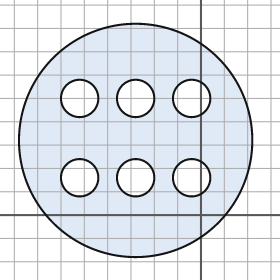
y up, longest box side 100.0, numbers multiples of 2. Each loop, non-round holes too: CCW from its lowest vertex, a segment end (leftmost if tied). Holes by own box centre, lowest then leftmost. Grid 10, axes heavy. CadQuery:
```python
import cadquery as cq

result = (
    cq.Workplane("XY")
    .moveTo(-28.0, 32.0)
    .circle(50.0)
    .moveTo(-52.0, 16.0)
    .circle(8.0)
    .moveTo(-28.0, 16.0)
    .circle(8.0)
    .moveTo(-4.0, 16.0)
    .circle(8.0)
    .moveTo(-52.0, 50.0)
    .circle(8.0)
    .moveTo(-28.0, 50.0)
    .circle(8.0)
    .moveTo(-4.0, 50.0)
    .circle(8.0)
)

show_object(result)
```